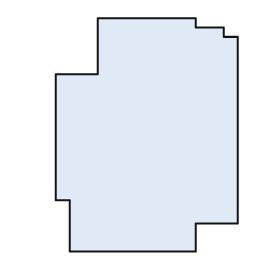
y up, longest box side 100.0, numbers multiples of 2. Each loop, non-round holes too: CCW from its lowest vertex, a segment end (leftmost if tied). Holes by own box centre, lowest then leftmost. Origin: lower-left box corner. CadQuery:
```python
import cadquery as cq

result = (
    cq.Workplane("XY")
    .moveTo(6.0, 0.0)
    .lineTo(60.0, 0.0)
    .lineTo(60.0, 12.0)
    .lineTo(78.0, 12.0)
    .lineTo(78.0, 92.0)
    .lineTo(72.0, 92.0)
    .lineTo(72.0, 96.0)
    .lineTo(60.0, 96.0)
    .lineTo(60.0, 100.0)
    .lineTo(18.0, 100.0)
    .lineTo(18.0, 76.0)
    .lineTo(0.0, 76.0)
    .lineTo(0.0, 22.0)
    .lineTo(6.0, 22.0)
    .close()
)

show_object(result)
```